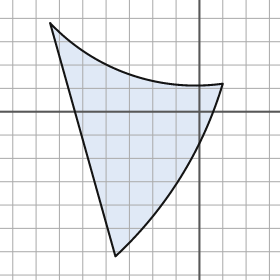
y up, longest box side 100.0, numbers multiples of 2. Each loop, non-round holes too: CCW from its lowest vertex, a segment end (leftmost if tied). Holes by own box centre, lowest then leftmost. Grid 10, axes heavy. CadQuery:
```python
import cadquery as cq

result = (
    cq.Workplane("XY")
    .moveTo(-36.0, -62.0)
    .threePointArc((-8.0, -28.0), (10.0, 12.0))
    .threePointArc((-30.0, 16.0), (-64.0, 38.0))
    .close()
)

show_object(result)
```